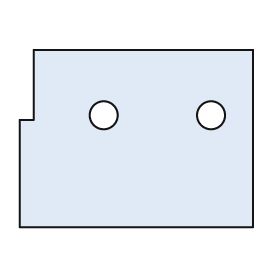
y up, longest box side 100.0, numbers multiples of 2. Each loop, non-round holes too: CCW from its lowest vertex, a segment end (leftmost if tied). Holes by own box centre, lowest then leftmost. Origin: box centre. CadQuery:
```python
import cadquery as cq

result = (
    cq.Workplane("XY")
    .moveTo(-50.0, -38.0)
    .lineTo(50.0, -38.0)
    .lineTo(50.0, 38.0)
    .lineTo(-44.0, 38.0)
    .lineTo(-44.0, 8.0)
    .lineTo(-50.0, 8.0)
    .close()
    .moveTo(-14.0, 10.0)
    .circle(6.0)
    .moveTo(32.0, 10.0)
    .circle(6.0)
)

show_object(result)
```